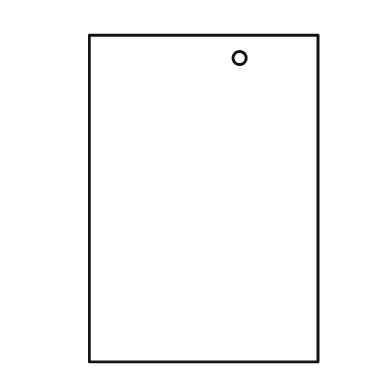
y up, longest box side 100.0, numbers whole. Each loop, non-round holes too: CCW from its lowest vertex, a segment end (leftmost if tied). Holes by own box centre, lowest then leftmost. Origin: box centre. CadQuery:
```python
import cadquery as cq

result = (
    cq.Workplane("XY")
    .moveTo(-35.0, -50.0)
    .lineTo(35.0, -50.0)
    .lineTo(35.0, 50.0)
    .lineTo(-35.0, 50.0)
    .close()
    .moveTo(11.0, 43.0)
    .circle(2.0)
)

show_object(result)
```